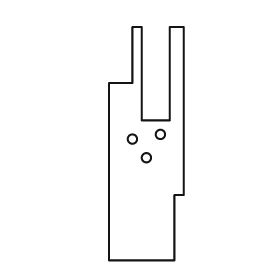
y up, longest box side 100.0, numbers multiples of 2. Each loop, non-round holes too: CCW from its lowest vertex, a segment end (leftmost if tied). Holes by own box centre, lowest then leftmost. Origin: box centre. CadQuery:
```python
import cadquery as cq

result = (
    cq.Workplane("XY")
    .moveTo(-16.0, -50.0)
    .lineTo(12.0, -50.0)
    .lineTo(12.0, -22.0)
    .lineTo(16.0, -22.0)
    .lineTo(16.0, 50.0)
    .lineTo(10.0, 50.0)
    .lineTo(10.0, 10.0)
    .lineTo(-2.0, 10.0)
    .lineTo(-2.0, 50.0)
    .lineTo(-6.0, 50.0)
    .lineTo(-6.0, 26.0)
    .lineTo(-16.0, 26.0)
    .close()
    .moveTo(0.0, -6.0)
    .circle(2.0)
    .moveTo(-6.0, 2.0)
    .circle(2.0)
    .moveTo(6.0, 4.0)
    .circle(2.0)
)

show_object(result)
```